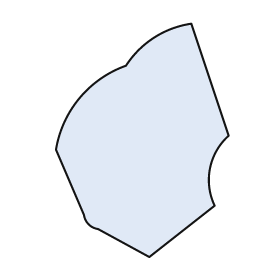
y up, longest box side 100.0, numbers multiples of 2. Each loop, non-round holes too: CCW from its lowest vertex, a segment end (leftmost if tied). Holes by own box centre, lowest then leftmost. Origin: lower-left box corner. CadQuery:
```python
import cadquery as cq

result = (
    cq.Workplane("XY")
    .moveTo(40.0, 0.0)
    .lineTo(68.0, 22.0)
    .threePointArc((66.0, 38.0), (74.0, 52.0))
    .lineTo(58.0, 100.0)
    .threePointArc((42.0, 94.0), (30.0, 82.0))
    .threePointArc((10.0, 68.0), (0.0, 46.0))
    .lineTo(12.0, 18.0)
    .threePointArc((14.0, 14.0), (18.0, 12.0))
    .close()
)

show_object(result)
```